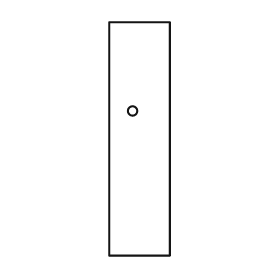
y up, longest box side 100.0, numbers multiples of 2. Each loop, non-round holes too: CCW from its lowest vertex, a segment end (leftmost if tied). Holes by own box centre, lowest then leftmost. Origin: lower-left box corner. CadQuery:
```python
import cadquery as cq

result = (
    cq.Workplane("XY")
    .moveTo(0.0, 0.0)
    .lineTo(26.0, 0.0)
    .lineTo(26.0, 100.0)
    .lineTo(0.0, 100.0)
    .close()
    .moveTo(10.0, 62.0)
    .circle(2.0)
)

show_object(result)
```